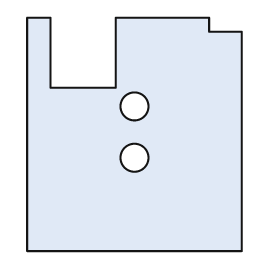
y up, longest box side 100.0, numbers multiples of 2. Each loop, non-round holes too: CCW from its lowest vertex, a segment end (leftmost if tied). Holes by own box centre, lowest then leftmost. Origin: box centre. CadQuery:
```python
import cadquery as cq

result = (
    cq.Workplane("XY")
    .moveTo(-46.0, -50.0)
    .lineTo(46.0, -50.0)
    .lineTo(46.0, 44.0)
    .lineTo(32.0, 44.0)
    .lineTo(32.0, 50.0)
    .lineTo(-8.0, 50.0)
    .lineTo(-8.0, 20.0)
    .lineTo(-36.0, 20.0)
    .lineTo(-36.0, 50.0)
    .lineTo(-46.0, 50.0)
    .close()
    .moveTo(0.0, -10.0)
    .circle(6.0)
    .moveTo(0.0, 12.0)
    .circle(6.0)
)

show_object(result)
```